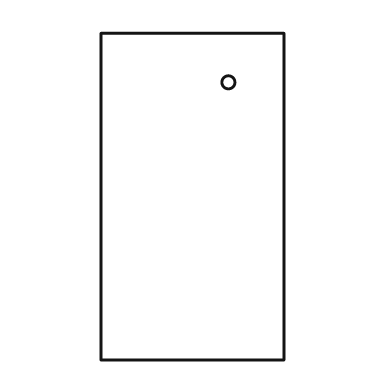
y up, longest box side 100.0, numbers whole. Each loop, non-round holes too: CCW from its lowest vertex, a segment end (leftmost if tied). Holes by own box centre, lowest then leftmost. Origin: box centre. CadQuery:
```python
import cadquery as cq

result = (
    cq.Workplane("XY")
    .moveTo(-28.0, -50.0)
    .lineTo(28.0, -50.0)
    .lineTo(28.0, 50.0)
    .lineTo(-28.0, 50.0)
    .close()
    .moveTo(11.0, 35.0)
    .circle(2.0)
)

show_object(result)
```